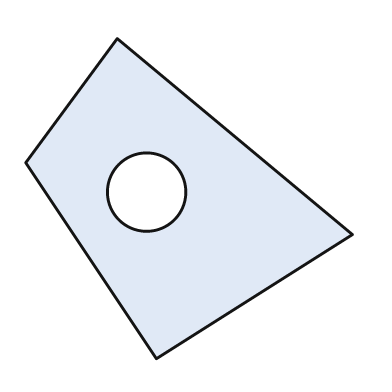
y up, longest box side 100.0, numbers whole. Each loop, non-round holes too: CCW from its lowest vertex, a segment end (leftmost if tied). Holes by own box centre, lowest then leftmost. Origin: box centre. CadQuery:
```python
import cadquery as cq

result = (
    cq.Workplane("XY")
    .moveTo(-10.0, -49.0)
    .lineTo(50.0, -11.0)
    .lineTo(-22.0, 49.0)
    .lineTo(-50.0, 11.0)
    .close()
    .moveTo(-13.0, 2.0)
    .circle(12.0)
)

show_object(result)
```